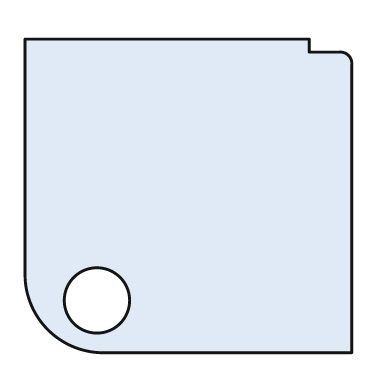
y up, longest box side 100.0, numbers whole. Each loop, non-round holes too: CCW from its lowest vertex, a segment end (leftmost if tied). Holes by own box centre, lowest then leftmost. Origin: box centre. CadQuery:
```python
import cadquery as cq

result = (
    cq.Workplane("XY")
    .moveTo(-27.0, -48.0)
    .lineTo(50.0, -48.0)
    .lineTo(50.0, 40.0)
    .threePointArc((49.0, 43.0), (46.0, 44.0))
    .lineTo(37.0, 44.0)
    .lineTo(37.0, 48.0)
    .lineTo(-50.0, 48.0)
    .lineTo(-50.0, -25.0)
    .threePointArc((-43.0, -41.0), (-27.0, -48.0))
    .close()
    .moveTo(-28.0, -32.0)
    .circle(10.0)
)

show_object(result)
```